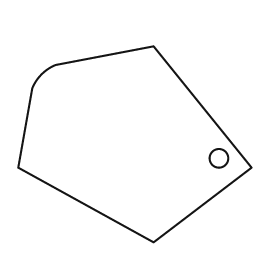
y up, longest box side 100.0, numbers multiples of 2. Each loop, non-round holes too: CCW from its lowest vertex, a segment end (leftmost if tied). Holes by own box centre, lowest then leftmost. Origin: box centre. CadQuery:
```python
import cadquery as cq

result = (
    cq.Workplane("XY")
    .moveTo(8.0, -42.0)
    .lineTo(50.0, -10.0)
    .lineTo(8.0, 42.0)
    .lineTo(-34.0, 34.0)
    .threePointArc((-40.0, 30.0), (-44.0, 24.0))
    .lineTo(-50.0, -10.0)
    .close()
    .moveTo(36.0, -6.0)
    .circle(4.0)
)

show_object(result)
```